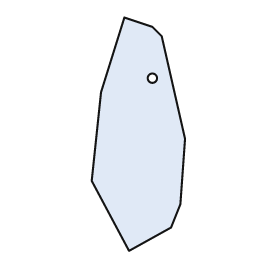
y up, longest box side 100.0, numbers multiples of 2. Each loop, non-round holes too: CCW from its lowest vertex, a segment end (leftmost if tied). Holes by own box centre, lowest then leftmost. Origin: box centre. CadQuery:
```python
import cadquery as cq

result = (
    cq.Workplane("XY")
    .moveTo(-4.0, -50.0)
    .lineTo(14.0, -40.0)
    .lineTo(18.0, -30.0)
    .lineTo(20.0, -2.0)
    .lineTo(10.0, 42.0)
    .lineTo(6.0, 46.0)
    .lineTo(-6.0, 50.0)
    .lineTo(-16.0, 18.0)
    .lineTo(-20.0, -20.0)
    .close()
    .moveTo(6.0, 24.0)
    .circle(2.0)
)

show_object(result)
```